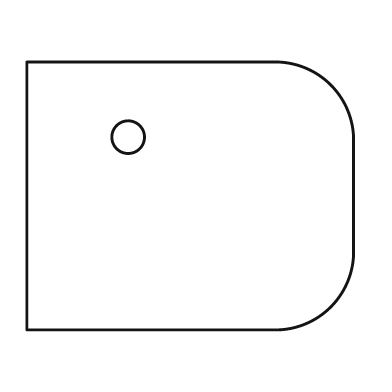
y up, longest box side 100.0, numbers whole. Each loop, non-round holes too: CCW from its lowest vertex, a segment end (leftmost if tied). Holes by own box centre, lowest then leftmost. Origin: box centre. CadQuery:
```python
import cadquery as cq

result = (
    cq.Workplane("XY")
    .moveTo(-50.0, -41.0)
    .lineTo(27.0, -41.0)
    .threePointArc((43.0, -34.0), (50.0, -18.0))
    .lineTo(50.0, 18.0)
    .threePointArc((43.0, 34.0), (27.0, 41.0))
    .lineTo(-50.0, 41.0)
    .close()
    .moveTo(-19.0, 18.0)
    .circle(5.0)
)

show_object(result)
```